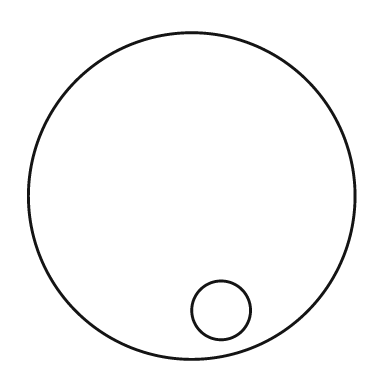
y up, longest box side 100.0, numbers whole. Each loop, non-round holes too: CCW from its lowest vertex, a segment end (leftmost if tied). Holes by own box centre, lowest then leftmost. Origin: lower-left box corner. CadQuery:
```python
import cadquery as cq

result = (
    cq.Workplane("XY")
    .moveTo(50.0, 50.0)
    .circle(50.0)
    .moveTo(59.0, 15.0)
    .circle(9.0)
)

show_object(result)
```